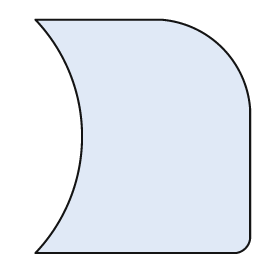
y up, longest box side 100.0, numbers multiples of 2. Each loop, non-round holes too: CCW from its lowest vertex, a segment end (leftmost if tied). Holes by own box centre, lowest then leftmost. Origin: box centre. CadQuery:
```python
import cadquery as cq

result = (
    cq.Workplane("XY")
    .moveTo(-46.0, -50.0)
    .lineTo(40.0, -50.0)
    .threePointArc((44.0, -48.0), (46.0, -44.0))
    .lineTo(46.0, 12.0)
    .threePointArc((34.0, 38.0), (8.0, 50.0))
    .lineTo(-46.0, 50.0)
    .threePointArc((-26.0, 0.0), (-46.0, -50.0))
    .close()
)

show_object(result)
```